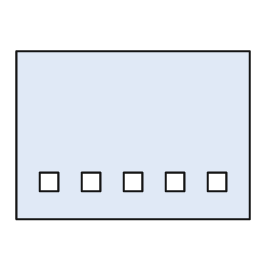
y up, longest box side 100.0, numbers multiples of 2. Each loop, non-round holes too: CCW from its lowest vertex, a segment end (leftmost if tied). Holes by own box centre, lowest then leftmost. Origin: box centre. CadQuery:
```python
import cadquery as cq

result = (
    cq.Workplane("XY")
    .moveTo(-50.0, -36.0)
    .lineTo(50.0, -36.0)
    .lineTo(50.0, 36.0)
    .lineTo(-50.0, 36.0)
    .close()
    .moveTo(-40.0, -24.0)
    .lineTo(-32.0, -24.0)
    .lineTo(-32.0, -16.0)
    .lineTo(-40.0, -16.0)
    .close()
    .moveTo(-22.0, -24.0)
    .lineTo(-14.0, -24.0)
    .lineTo(-14.0, -16.0)
    .lineTo(-22.0, -16.0)
    .close()
    .moveTo(-4.0, -24.0)
    .lineTo(4.0, -24.0)
    .lineTo(4.0, -16.0)
    .lineTo(-4.0, -16.0)
    .close()
    .moveTo(14.0, -24.0)
    .lineTo(22.0, -24.0)
    .lineTo(22.0, -16.0)
    .lineTo(14.0, -16.0)
    .close()
    .moveTo(32.0, -24.0)
    .lineTo(40.0, -24.0)
    .lineTo(40.0, -16.0)
    .lineTo(32.0, -16.0)
    .close()
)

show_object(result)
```